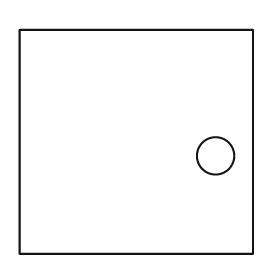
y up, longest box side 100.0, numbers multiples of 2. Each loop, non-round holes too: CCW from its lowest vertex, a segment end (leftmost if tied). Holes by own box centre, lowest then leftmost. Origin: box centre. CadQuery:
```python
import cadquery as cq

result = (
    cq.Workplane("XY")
    .moveTo(-50.0, -48.0)
    .lineTo(50.0, -48.0)
    .lineTo(50.0, 48.0)
    .lineTo(-50.0, 48.0)
    .close()
    .moveTo(34.0, -6.0)
    .circle(8.0)
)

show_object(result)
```